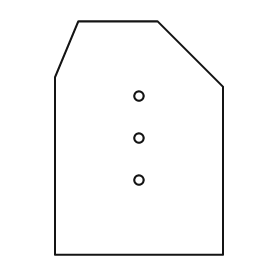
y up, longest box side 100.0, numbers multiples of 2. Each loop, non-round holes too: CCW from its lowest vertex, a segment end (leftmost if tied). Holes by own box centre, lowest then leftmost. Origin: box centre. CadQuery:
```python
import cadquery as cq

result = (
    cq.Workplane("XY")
    .moveTo(-36.0, -50.0)
    .lineTo(36.0, -50.0)
    .lineTo(36.0, 22.0)
    .lineTo(8.0, 50.0)
    .lineTo(-26.0, 50.0)
    .lineTo(-36.0, 26.0)
    .close()
    .moveTo(0.0, -18.0)
    .circle(2.0)
    .moveTo(0.0, 0.0)
    .circle(2.0)
    .moveTo(0.0, 18.0)
    .circle(2.0)
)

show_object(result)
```